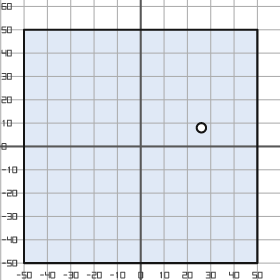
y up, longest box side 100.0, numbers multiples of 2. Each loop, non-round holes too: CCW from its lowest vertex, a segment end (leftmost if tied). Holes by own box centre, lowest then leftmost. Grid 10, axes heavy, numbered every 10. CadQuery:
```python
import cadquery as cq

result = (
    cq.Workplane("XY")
    .moveTo(-50.0, -50.0)
    .lineTo(50.0, -50.0)
    .lineTo(50.0, 50.0)
    .lineTo(-50.0, 50.0)
    .close()
    .moveTo(26.0, 8.0)
    .circle(2.0)
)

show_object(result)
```